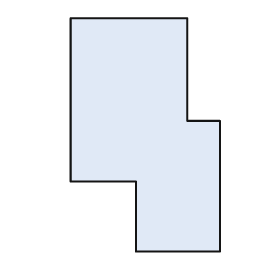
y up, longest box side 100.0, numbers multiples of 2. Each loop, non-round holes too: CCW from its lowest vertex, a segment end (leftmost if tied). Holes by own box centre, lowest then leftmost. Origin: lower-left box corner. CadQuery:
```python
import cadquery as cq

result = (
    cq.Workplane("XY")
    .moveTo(28.0, 0.0)
    .lineTo(64.0, 0.0)
    .lineTo(64.0, 56.0)
    .lineTo(50.0, 56.0)
    .lineTo(50.0, 100.0)
    .lineTo(0.0, 100.0)
    .lineTo(0.0, 30.0)
    .lineTo(28.0, 30.0)
    .close()
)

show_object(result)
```